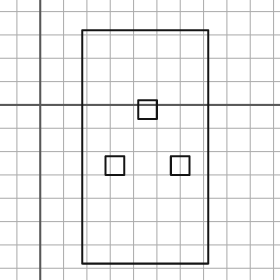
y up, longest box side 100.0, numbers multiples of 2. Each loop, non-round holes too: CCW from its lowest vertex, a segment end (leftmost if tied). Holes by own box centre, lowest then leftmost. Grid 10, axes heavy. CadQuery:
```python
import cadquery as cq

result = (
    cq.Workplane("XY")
    .moveTo(18.0, -68.0)
    .lineTo(72.0, -68.0)
    .lineTo(72.0, 32.0)
    .lineTo(18.0, 32.0)
    .close()
    .moveTo(28.0, -30.0)
    .lineTo(36.0, -30.0)
    .lineTo(36.0, -22.0)
    .lineTo(28.0, -22.0)
    .close()
    .moveTo(56.0, -30.0)
    .lineTo(64.0, -30.0)
    .lineTo(64.0, -22.0)
    .lineTo(56.0, -22.0)
    .close()
    .moveTo(42.0, -6.0)
    .lineTo(50.0, -6.0)
    .lineTo(50.0, 2.0)
    .lineTo(42.0, 2.0)
    .close()
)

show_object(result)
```